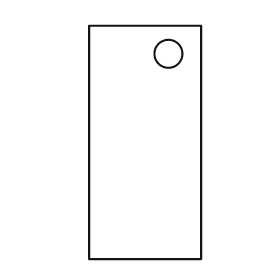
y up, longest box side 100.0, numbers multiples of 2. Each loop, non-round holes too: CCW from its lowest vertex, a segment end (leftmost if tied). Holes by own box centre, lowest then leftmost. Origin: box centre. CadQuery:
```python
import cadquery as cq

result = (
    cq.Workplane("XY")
    .moveTo(-24.0, -50.0)
    .lineTo(24.0, -50.0)
    .lineTo(24.0, 50.0)
    .lineTo(-24.0, 50.0)
    .close()
    .moveTo(10.0, 38.0)
    .circle(6.0)
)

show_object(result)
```